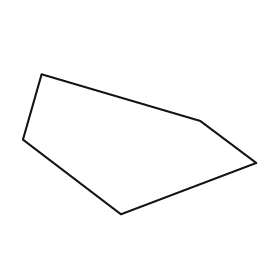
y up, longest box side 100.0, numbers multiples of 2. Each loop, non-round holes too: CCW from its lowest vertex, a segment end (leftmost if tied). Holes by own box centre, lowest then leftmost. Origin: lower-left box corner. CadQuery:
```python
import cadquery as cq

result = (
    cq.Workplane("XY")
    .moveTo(42.0, 0.0)
    .lineTo(100.0, 22.0)
    .lineTo(76.0, 40.0)
    .lineTo(8.0, 60.0)
    .lineTo(0.0, 32.0)
    .close()
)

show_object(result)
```